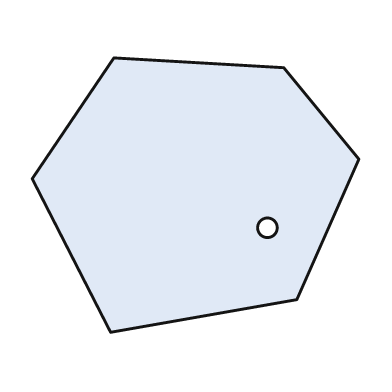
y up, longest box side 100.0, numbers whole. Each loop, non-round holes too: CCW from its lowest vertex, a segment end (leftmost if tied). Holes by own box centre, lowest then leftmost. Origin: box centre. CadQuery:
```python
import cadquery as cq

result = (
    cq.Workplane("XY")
    .moveTo(-26.0, -42.0)
    .lineTo(31.0, -32.0)
    .lineTo(50.0, 11.0)
    .lineTo(27.0, 39.0)
    .lineTo(-25.0, 42.0)
    .lineTo(-50.0, 5.0)
    .close()
    .moveTo(22.0, -10.0)
    .circle(3.0)
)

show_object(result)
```